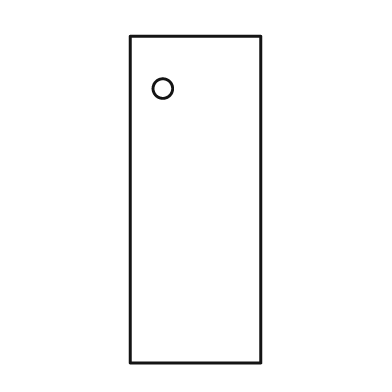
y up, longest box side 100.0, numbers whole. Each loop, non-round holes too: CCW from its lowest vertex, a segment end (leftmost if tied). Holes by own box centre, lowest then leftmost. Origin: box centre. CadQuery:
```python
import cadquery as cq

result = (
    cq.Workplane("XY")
    .moveTo(-20.0, -50.0)
    .lineTo(20.0, -50.0)
    .lineTo(20.0, 50.0)
    .lineTo(-20.0, 50.0)
    .close()
    .moveTo(-10.0, 34.0)
    .circle(3.0)
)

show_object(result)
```